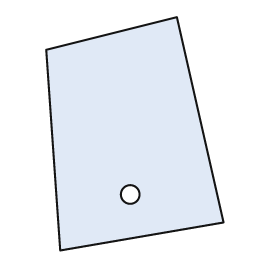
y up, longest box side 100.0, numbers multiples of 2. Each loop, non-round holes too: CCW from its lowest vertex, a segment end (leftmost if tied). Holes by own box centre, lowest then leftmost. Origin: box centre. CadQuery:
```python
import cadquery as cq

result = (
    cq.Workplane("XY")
    .moveTo(-32.0, -50.0)
    .lineTo(38.0, -38.0)
    .lineTo(18.0, 50.0)
    .lineTo(-38.0, 36.0)
    .close()
    .moveTo(-2.0, -26.0)
    .circle(4.0)
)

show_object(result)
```